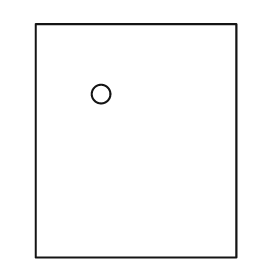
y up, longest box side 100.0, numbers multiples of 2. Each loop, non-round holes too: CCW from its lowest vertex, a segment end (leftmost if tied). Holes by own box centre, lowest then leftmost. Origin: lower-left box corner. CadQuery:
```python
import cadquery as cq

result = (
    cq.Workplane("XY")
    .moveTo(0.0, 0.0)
    .lineTo(86.0, 0.0)
    .lineTo(86.0, 100.0)
    .lineTo(0.0, 100.0)
    .close()
    .moveTo(28.0, 70.0)
    .circle(4.0)
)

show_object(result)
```